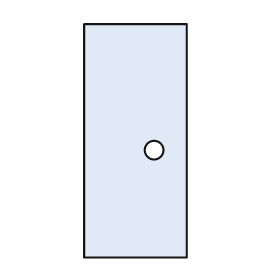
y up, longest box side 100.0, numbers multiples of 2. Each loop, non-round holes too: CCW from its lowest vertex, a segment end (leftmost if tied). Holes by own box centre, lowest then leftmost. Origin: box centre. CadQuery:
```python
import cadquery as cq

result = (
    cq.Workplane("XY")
    .moveTo(-22.0, -50.0)
    .lineTo(22.0, -50.0)
    .lineTo(22.0, 50.0)
    .lineTo(-22.0, 50.0)
    .close()
    .moveTo(8.0, -4.0)
    .circle(4.0)
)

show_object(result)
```